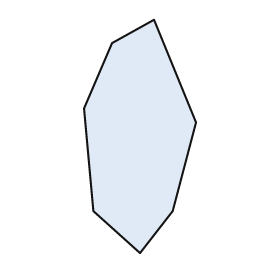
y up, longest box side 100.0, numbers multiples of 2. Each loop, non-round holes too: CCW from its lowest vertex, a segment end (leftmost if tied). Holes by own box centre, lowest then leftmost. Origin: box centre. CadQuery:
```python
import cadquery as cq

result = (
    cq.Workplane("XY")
    .moveTo(0.0, -50.0)
    .lineTo(14.0, -32.0)
    .lineTo(24.0, 6.0)
    .lineTo(6.0, 50.0)
    .lineTo(-12.0, 40.0)
    .lineTo(-24.0, 12.0)
    .lineTo(-20.0, -32.0)
    .close()
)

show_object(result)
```